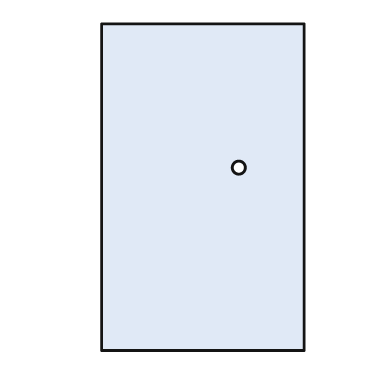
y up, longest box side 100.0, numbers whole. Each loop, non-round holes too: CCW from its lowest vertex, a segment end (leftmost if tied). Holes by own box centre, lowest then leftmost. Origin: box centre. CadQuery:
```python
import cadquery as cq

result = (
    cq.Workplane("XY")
    .moveTo(-31.0, -50.0)
    .lineTo(31.0, -50.0)
    .lineTo(31.0, 50.0)
    .lineTo(-31.0, 50.0)
    .close()
    .moveTo(11.0, 6.0)
    .circle(2.0)
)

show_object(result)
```